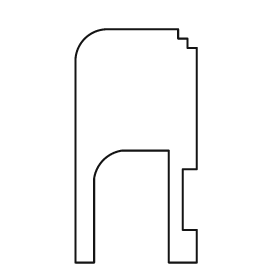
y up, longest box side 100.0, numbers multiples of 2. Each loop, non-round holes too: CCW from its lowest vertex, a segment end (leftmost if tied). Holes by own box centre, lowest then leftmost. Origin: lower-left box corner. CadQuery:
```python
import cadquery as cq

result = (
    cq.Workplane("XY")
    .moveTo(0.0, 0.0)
    .lineTo(8.0, 0.0)
    .lineTo(8.0, 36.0)
    .threePointArc((12.0, 44.0), (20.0, 48.0))
    .lineTo(40.0, 48.0)
    .lineTo(40.0, 0.0)
    .lineTo(52.0, 0.0)
    .lineTo(52.0, 14.0)
    .lineTo(46.0, 14.0)
    .lineTo(46.0, 40.0)
    .lineTo(52.0, 40.0)
    .lineTo(52.0, 92.0)
    .lineTo(48.0, 92.0)
    .lineTo(48.0, 96.0)
    .lineTo(44.0, 96.0)
    .lineTo(44.0, 100.0)
    .lineTo(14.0, 100.0)
    .threePointArc((4.0, 96.0), (0.0, 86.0))
    .close()
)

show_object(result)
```